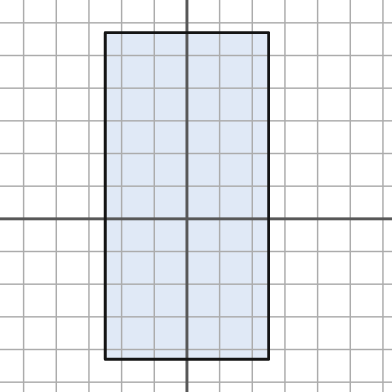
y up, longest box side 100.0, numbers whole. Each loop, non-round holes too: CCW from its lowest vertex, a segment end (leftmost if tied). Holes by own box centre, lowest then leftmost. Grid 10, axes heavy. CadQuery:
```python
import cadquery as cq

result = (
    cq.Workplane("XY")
    .moveTo(-25.0, -43.0)
    .lineTo(25.0, -43.0)
    .lineTo(25.0, 57.0)
    .lineTo(-25.0, 57.0)
    .close()
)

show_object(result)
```